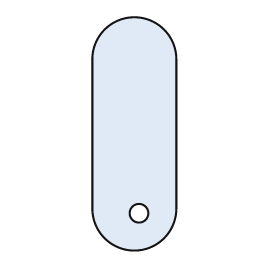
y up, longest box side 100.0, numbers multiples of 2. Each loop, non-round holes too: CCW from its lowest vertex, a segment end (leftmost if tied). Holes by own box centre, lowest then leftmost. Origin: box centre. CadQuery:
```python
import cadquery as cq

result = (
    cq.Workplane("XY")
    .moveTo(-18.0, -32.0)
    .threePointArc((0.0, -50.0), (18.0, -32.0))
    .lineTo(18.0, 32.0)
    .threePointArc((0.0, 50.0), (-18.0, 32.0))
    .close()
    .moveTo(2.0, -34.0)
    .circle(4.0)
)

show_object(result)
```